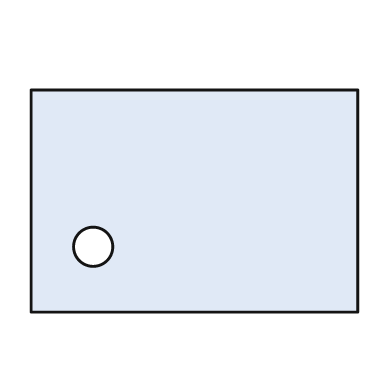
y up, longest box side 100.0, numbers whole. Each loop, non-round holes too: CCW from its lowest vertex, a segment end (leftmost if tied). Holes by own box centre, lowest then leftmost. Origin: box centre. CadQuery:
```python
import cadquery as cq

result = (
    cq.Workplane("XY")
    .moveTo(-50.0, -34.0)
    .lineTo(50.0, -34.0)
    .lineTo(50.0, 34.0)
    .lineTo(-50.0, 34.0)
    .close()
    .moveTo(-31.0, -14.0)
    .circle(6.0)
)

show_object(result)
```